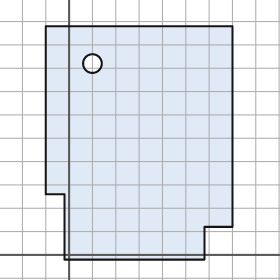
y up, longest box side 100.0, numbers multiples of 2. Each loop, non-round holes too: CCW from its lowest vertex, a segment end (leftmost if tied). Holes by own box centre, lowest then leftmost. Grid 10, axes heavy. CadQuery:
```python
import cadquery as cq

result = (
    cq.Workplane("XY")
    .moveTo(-2.0, -2.0)
    .lineTo(58.0, -2.0)
    .lineTo(58.0, 12.0)
    .lineTo(70.0, 12.0)
    .lineTo(70.0, 98.0)
    .lineTo(-10.0, 98.0)
    .lineTo(-10.0, 26.0)
    .lineTo(-2.0, 26.0)
    .close()
    .moveTo(10.0, 82.0)
    .circle(4.0)
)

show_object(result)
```